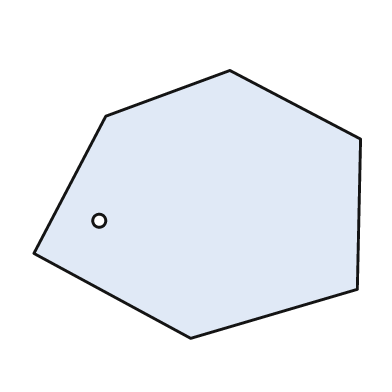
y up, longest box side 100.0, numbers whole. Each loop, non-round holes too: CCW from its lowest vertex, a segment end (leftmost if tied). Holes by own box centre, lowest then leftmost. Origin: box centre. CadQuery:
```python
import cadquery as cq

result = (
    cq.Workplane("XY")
    .moveTo(-2.0, -41.0)
    .lineTo(49.0, -26.0)
    .lineTo(50.0, 20.0)
    .lineTo(10.0, 41.0)
    .lineTo(-28.0, 27.0)
    .lineTo(-50.0, -15.0)
    .close()
    .moveTo(-30.0, -5.0)
    .circle(2.0)
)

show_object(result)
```